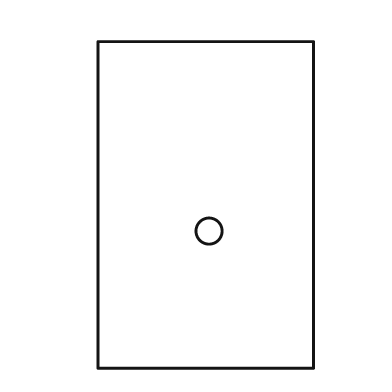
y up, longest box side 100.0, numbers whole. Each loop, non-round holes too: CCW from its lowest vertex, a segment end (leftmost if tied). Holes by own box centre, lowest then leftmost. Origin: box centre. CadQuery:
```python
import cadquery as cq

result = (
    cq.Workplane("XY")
    .moveTo(-33.0, -50.0)
    .lineTo(33.0, -50.0)
    .lineTo(33.0, 50.0)
    .lineTo(-33.0, 50.0)
    .close()
    .moveTo(1.0, -8.0)
    .circle(4.0)
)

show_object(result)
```